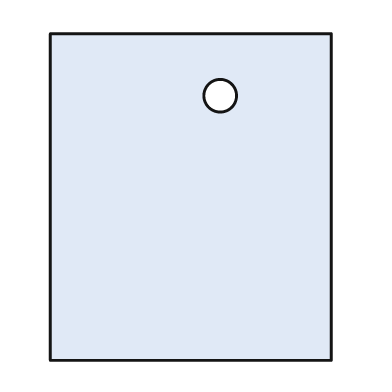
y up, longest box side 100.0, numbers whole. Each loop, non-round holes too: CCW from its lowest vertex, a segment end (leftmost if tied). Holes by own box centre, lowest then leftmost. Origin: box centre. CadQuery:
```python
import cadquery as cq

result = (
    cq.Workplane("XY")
    .moveTo(-43.0, -50.0)
    .lineTo(43.0, -50.0)
    .lineTo(43.0, 50.0)
    .lineTo(-43.0, 50.0)
    .close()
    .moveTo(9.0, 31.0)
    .circle(5.0)
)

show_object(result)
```